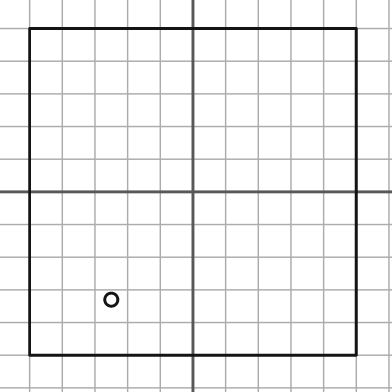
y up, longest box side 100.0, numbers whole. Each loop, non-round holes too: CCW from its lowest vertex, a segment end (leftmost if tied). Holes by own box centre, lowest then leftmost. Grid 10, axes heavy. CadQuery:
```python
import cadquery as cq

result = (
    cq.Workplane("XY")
    .moveTo(-50.0, -50.0)
    .lineTo(50.0, -50.0)
    .lineTo(50.0, 50.0)
    .lineTo(-50.0, 50.0)
    .close()
    .moveTo(-25.0, -33.0)
    .circle(2.0)
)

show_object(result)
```